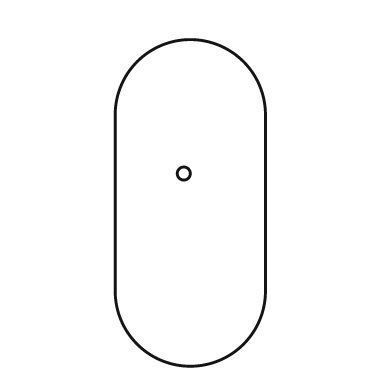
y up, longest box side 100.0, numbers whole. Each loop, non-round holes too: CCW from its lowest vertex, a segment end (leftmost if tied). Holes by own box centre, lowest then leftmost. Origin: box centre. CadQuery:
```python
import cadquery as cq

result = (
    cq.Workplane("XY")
    .moveTo(-23.0, -27.0)
    .threePointArc((0.0, -50.0), (23.0, -27.0))
    .lineTo(23.0, 27.0)
    .threePointArc((0.0, 50.0), (-23.0, 27.0))
    .close()
    .moveTo(-2.0, 9.0)
    .circle(2.0)
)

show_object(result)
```